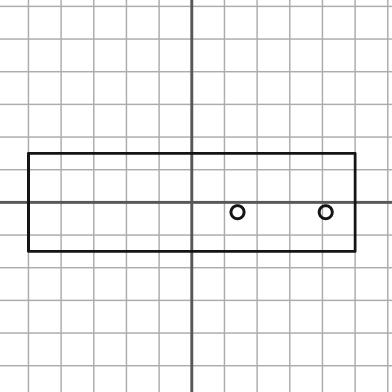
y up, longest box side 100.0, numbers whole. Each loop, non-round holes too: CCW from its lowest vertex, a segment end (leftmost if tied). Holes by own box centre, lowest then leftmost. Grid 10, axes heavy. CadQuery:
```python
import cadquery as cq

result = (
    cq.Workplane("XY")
    .moveTo(-50.0, -15.0)
    .lineTo(50.0, -15.0)
    .lineTo(50.0, 15.0)
    .lineTo(-50.0, 15.0)
    .close()
    .moveTo(14.0, -3.0)
    .circle(2.0)
    .moveTo(41.0, -3.0)
    .circle(2.0)
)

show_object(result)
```